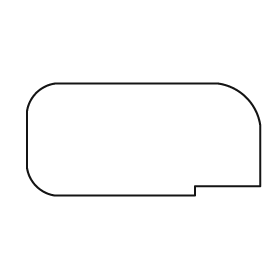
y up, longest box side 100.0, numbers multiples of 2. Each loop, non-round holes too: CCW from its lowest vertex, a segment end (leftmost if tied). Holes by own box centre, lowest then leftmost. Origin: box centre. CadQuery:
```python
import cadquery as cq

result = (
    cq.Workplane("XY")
    .moveTo(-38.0, -24.0)
    .lineTo(22.0, -24.0)
    .lineTo(22.0, -20.0)
    .lineTo(50.0, -20.0)
    .lineTo(50.0, 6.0)
    .threePointArc((44.0, 18.0), (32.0, 24.0))
    .lineTo(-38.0, 24.0)
    .threePointArc((-46.0, 20.0), (-50.0, 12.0))
    .lineTo(-50.0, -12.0)
    .threePointArc((-46.0, -20.0), (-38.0, -24.0))
    .close()
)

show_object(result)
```